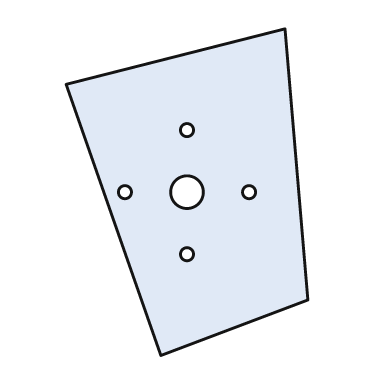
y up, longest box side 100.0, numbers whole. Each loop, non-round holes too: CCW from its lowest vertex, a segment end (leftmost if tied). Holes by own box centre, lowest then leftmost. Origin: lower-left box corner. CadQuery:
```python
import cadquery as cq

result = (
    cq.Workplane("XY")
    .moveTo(29.0, 0.0)
    .lineTo(74.0, 17.0)
    .lineTo(67.0, 100.0)
    .lineTo(0.0, 83.0)
    .close()
    .moveTo(37.0, 31.0)
    .circle(2.0)
    .moveTo(18.0, 50.0)
    .circle(2.0)
    .moveTo(37.0, 50.0)
    .circle(5.0)
    .moveTo(56.0, 50.0)
    .circle(2.0)
    .moveTo(37.0, 69.0)
    .circle(2.0)
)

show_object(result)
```